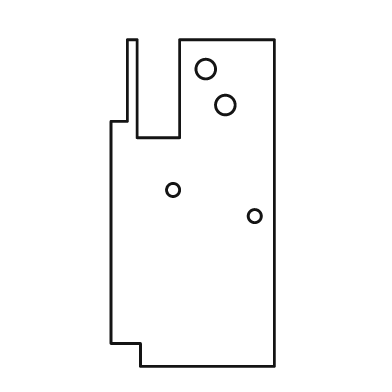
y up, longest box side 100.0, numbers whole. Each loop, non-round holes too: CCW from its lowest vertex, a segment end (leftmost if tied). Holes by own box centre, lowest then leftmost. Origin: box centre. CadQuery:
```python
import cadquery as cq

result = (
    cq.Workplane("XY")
    .moveTo(-16.0, -50.0)
    .lineTo(25.0, -50.0)
    .lineTo(25.0, 50.0)
    .lineTo(-4.0, 50.0)
    .lineTo(-4.0, 20.0)
    .lineTo(-17.0, 20.0)
    .lineTo(-17.0, 50.0)
    .lineTo(-20.0, 50.0)
    .lineTo(-20.0, 25.0)
    .lineTo(-25.0, 25.0)
    .lineTo(-25.0, -43.0)
    .lineTo(-16.0, -43.0)
    .close()
    .moveTo(19.0, -4.0)
    .circle(2.0)
    .moveTo(-6.0, 4.0)
    .circle(2.0)
    .moveTo(10.0, 30.0)
    .circle(3.0)
    .moveTo(4.0, 41.0)
    .circle(3.0)
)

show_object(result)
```